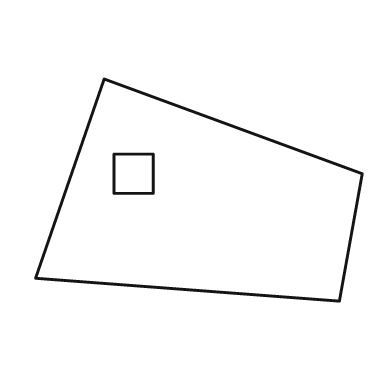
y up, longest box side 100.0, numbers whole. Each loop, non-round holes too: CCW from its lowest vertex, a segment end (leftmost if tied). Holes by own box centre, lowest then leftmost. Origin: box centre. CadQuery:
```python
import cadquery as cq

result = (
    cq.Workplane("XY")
    .moveTo(43.0, -34.0)
    .lineTo(50.0, 5.0)
    .lineTo(-29.0, 34.0)
    .lineTo(-50.0, -27.0)
    .close()
    .moveTo(-26.0, -1.0)
    .lineTo(-14.0, -1.0)
    .lineTo(-14.0, 11.0)
    .lineTo(-26.0, 11.0)
    .close()
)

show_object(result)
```